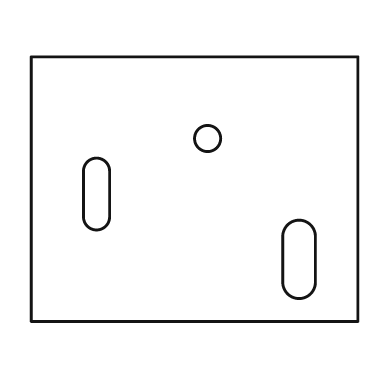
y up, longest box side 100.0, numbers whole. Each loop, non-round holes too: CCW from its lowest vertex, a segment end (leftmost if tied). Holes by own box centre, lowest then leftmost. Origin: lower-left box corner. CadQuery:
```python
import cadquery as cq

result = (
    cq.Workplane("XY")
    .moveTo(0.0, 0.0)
    .lineTo(100.0, 0.0)
    .lineTo(100.0, 81.0)
    .lineTo(0.0, 81.0)
    .close()
    .moveTo(77.0, 12.0)
    .threePointArc((82.0, 7.0), (87.0, 12.0))
    .lineTo(87.0, 26.0)
    .threePointArc((82.0, 31.0), (77.0, 26.0))
    .close()
    .moveTo(16.0, 32.0)
    .threePointArc((20.0, 28.0), (24.0, 32.0))
    .lineTo(24.0, 46.0)
    .threePointArc((20.0, 50.0), (16.0, 46.0))
    .close()
    .moveTo(54.0, 56.0)
    .circle(4.0)
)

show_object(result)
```